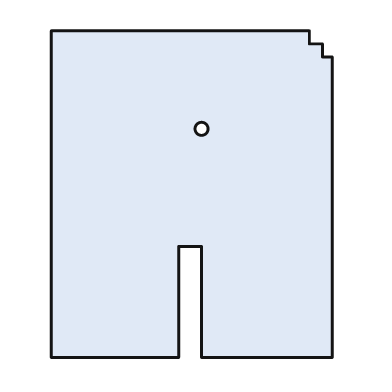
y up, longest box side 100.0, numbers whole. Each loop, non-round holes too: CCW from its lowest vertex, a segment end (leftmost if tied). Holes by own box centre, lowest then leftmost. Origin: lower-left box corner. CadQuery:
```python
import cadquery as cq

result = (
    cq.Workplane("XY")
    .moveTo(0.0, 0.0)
    .lineTo(39.0, 0.0)
    .lineTo(39.0, 34.0)
    .lineTo(46.0, 34.0)
    .lineTo(46.0, 0.0)
    .lineTo(86.0, 0.0)
    .lineTo(86.0, 92.0)
    .lineTo(83.0, 92.0)
    .lineTo(83.0, 96.0)
    .lineTo(79.0, 96.0)
    .lineTo(79.0, 100.0)
    .lineTo(0.0, 100.0)
    .close()
    .moveTo(46.0, 70.0)
    .circle(2.0)
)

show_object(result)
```